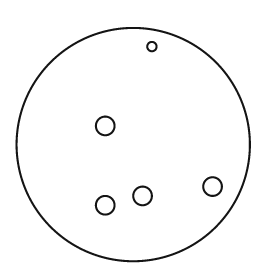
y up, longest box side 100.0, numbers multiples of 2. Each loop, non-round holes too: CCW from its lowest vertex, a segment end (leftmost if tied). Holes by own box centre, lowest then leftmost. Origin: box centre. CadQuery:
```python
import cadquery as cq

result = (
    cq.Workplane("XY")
    .moveTo(0.0, 0.0)
    .circle(50.0)
    .moveTo(-12.0, -26.0)
    .circle(4.0)
    .moveTo(4.0, -22.0)
    .circle(4.0)
    .moveTo(34.0, -18.0)
    .circle(4.0)
    .moveTo(-12.0, 8.0)
    .circle(4.0)
    .moveTo(8.0, 42.0)
    .circle(2.0)
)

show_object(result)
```